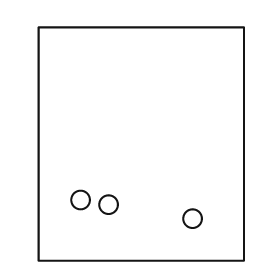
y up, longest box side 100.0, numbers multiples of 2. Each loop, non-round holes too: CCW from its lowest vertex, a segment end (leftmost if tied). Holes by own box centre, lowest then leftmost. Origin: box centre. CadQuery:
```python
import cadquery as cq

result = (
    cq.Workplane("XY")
    .moveTo(-44.0, -50.0)
    .lineTo(44.0, -50.0)
    .lineTo(44.0, 50.0)
    .lineTo(-44.0, 50.0)
    .close()
    .moveTo(22.0, -32.0)
    .circle(4.0)
    .moveTo(-14.0, -26.0)
    .circle(4.0)
    .moveTo(-26.0, -24.0)
    .circle(4.0)
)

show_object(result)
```